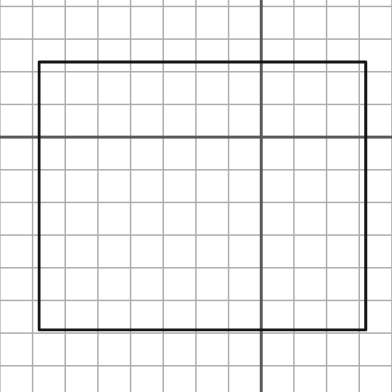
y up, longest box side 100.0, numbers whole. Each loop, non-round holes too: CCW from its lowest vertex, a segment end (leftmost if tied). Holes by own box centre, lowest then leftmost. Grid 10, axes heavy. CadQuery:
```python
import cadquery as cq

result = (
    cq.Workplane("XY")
    .moveTo(-68.0, -59.0)
    .lineTo(32.0, -59.0)
    .lineTo(32.0, 23.0)
    .lineTo(-68.0, 23.0)
    .close()
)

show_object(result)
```